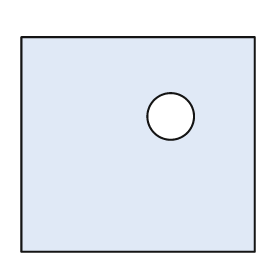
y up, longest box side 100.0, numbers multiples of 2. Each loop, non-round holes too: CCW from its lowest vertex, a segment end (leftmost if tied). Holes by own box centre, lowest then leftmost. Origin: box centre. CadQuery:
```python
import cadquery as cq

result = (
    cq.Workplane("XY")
    .moveTo(-50.0, -46.0)
    .lineTo(50.0, -46.0)
    .lineTo(50.0, 46.0)
    .lineTo(-50.0, 46.0)
    .close()
    .moveTo(14.0, 12.0)
    .circle(10.0)
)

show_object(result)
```